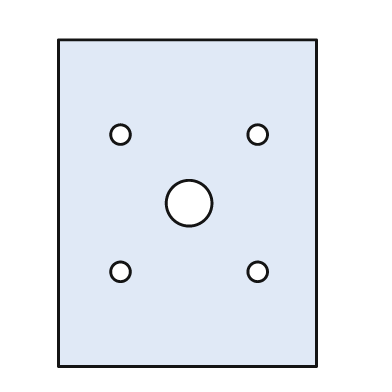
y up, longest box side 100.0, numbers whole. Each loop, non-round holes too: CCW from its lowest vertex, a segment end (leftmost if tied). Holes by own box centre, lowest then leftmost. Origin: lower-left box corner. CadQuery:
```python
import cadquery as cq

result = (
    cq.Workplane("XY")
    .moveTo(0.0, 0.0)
    .lineTo(79.0, 0.0)
    .lineTo(79.0, 100.0)
    .lineTo(0.0, 100.0)
    .close()
    .moveTo(19.0, 29.0)
    .circle(3.0)
    .moveTo(61.0, 29.0)
    .circle(3.0)
    .moveTo(40.0, 50.0)
    .circle(7.0)
    .moveTo(19.0, 71.0)
    .circle(3.0)
    .moveTo(61.0, 71.0)
    .circle(3.0)
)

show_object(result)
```